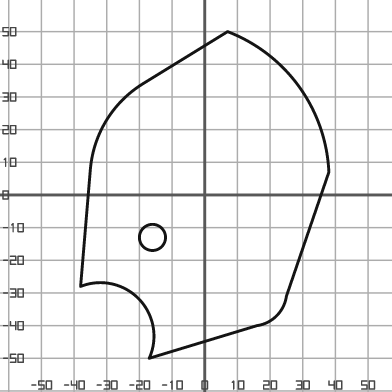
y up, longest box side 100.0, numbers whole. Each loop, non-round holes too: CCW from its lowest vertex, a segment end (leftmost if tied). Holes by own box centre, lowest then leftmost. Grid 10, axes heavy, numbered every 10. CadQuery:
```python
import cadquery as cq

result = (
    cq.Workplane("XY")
    .moveTo(-17.0, -50.0)
    .lineTo(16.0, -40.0)
    .threePointArc((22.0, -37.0), (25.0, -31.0))
    .lineTo(38.0, 7.0)
    .threePointArc((29.0, 33.0), (7.0, 50.0))
    .lineTo(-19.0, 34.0)
    .threePointArc((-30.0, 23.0), (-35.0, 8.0))
    .lineTo(-38.0, -28.0)
    .threePointArc((-20.0, -32.0), (-17.0, -50.0))
    .close()
    .moveTo(-16.0, -13.0)
    .circle(4.0)
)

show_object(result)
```